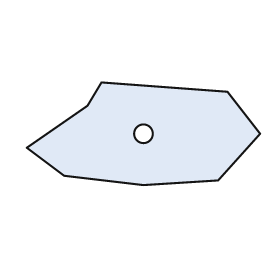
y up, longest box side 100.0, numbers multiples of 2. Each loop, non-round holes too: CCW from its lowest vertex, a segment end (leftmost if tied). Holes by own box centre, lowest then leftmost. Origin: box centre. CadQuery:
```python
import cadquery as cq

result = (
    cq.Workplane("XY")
    .moveTo(0.0, -22.0)
    .lineTo(32.0, -20.0)
    .lineTo(50.0, 0.0)
    .lineTo(36.0, 18.0)
    .lineTo(-18.0, 22.0)
    .lineTo(-24.0, 12.0)
    .lineTo(-50.0, -6.0)
    .lineTo(-34.0, -18.0)
    .close()
    .moveTo(0.0, 0.0)
    .circle(4.0)
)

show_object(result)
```